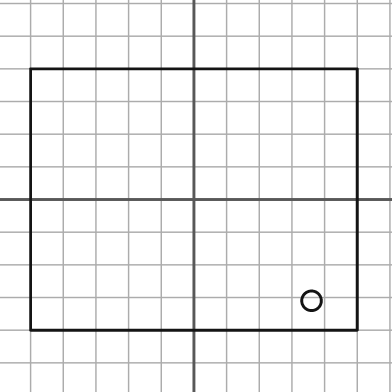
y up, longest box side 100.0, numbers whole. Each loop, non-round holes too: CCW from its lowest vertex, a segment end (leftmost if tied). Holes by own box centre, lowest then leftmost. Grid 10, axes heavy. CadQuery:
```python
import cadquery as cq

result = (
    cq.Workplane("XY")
    .moveTo(-50.0, -40.0)
    .lineTo(50.0, -40.0)
    .lineTo(50.0, 40.0)
    .lineTo(-50.0, 40.0)
    .close()
    .moveTo(36.0, -31.0)
    .circle(3.0)
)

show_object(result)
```